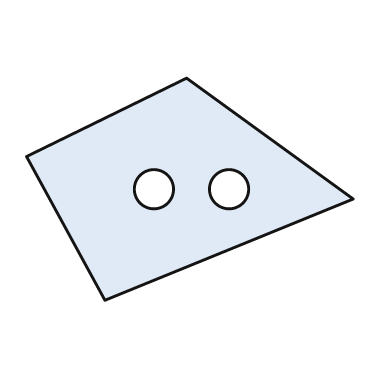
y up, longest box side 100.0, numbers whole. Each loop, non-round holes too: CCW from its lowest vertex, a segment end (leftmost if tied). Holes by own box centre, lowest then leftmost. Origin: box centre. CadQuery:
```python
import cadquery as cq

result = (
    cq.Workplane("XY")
    .moveTo(-26.0, -34.0)
    .lineTo(50.0, -3.0)
    .lineTo(-1.0, 34.0)
    .lineTo(-50.0, 10.0)
    .close()
    .moveTo(-11.0, 0.0)
    .circle(6.0)
    .moveTo(12.0, 0.0)
    .circle(6.0)
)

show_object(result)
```